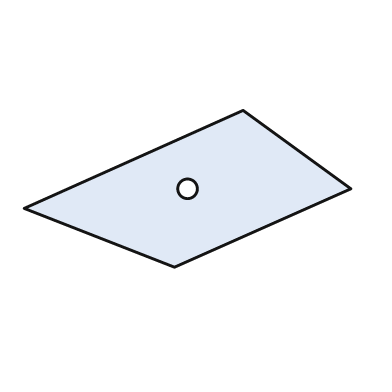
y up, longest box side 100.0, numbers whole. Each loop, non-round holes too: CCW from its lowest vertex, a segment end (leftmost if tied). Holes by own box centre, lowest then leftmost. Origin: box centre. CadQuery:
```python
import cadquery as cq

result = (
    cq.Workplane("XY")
    .moveTo(-4.0, -24.0)
    .lineTo(50.0, 0.0)
    .lineTo(17.0, 24.0)
    .lineTo(-50.0, -6.0)
    .close()
    .moveTo(0.0, 0.0)
    .circle(3.0)
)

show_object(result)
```